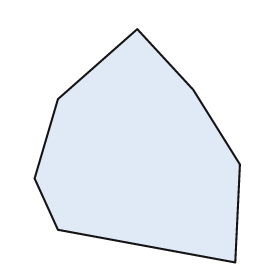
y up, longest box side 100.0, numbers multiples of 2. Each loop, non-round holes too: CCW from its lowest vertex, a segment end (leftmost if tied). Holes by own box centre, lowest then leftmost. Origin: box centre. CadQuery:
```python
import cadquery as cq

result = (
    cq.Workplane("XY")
    .moveTo(42.0, -50.0)
    .lineTo(44.0, -8.0)
    .lineTo(24.0, 24.0)
    .lineTo(0.0, 50.0)
    .lineTo(-34.0, 20.0)
    .lineTo(-44.0, -14.0)
    .lineTo(-34.0, -36.0)
    .close()
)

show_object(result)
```